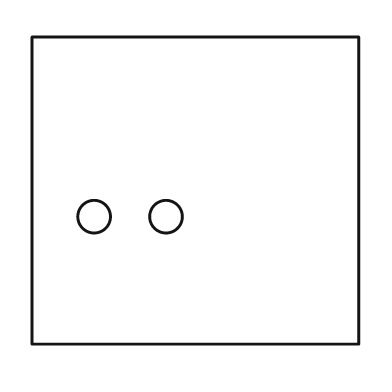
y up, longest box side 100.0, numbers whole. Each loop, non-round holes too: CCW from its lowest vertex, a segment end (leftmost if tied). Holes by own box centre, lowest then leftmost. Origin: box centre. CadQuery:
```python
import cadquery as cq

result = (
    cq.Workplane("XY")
    .moveTo(-50.0, -47.0)
    .lineTo(50.0, -47.0)
    .lineTo(50.0, 47.0)
    .lineTo(-50.0, 47.0)
    .close()
    .moveTo(-31.0, -8.0)
    .circle(5.0)
    .moveTo(-9.0, -8.0)
    .circle(5.0)
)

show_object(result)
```